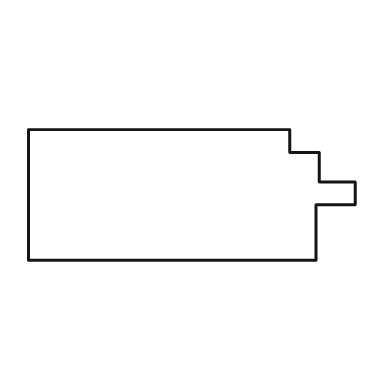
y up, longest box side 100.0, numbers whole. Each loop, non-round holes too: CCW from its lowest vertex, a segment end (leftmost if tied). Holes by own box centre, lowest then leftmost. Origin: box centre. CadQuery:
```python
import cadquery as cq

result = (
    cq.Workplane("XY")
    .moveTo(-50.0, -20.0)
    .lineTo(38.0, -20.0)
    .lineTo(38.0, -3.0)
    .lineTo(50.0, -3.0)
    .lineTo(50.0, 4.0)
    .lineTo(39.0, 4.0)
    .lineTo(39.0, 13.0)
    .lineTo(30.0, 13.0)
    .lineTo(30.0, 20.0)
    .lineTo(-50.0, 20.0)
    .close()
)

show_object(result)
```